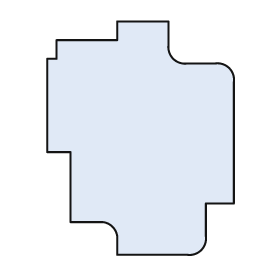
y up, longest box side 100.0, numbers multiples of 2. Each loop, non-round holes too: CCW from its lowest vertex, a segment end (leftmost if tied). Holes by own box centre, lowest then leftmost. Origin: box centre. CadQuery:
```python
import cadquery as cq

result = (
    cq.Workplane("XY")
    .moveTo(-10.0, -50.0)
    .lineTo(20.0, -50.0)
    .threePointArc((26.0, -48.0), (28.0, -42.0))
    .lineTo(28.0, -28.0)
    .lineTo(40.0, -28.0)
    .lineTo(40.0, 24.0)
    .threePointArc((38.0, 30.0), (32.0, 32.0))
    .lineTo(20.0, 32.0)
    .threePointArc((14.0, 34.0), (12.0, 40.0))
    .lineTo(12.0, 50.0)
    .lineTo(-10.0, 50.0)
    .lineTo(-10.0, 42.0)
    .lineTo(-36.0, 42.0)
    .lineTo(-36.0, 34.0)
    .lineTo(-40.0, 34.0)
    .lineTo(-40.0, -6.0)
    .lineTo(-30.0, -6.0)
    .lineTo(-30.0, -36.0)
    .lineTo(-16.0, -36.0)
    .threePointArc((-12.0, -38.0), (-10.0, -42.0))
    .close()
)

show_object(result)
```